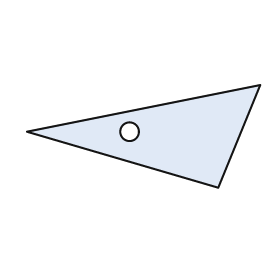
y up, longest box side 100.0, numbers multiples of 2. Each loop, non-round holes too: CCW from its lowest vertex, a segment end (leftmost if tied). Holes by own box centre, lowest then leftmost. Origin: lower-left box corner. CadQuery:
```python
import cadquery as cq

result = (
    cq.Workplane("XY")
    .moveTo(82.0, 0.0)
    .lineTo(100.0, 44.0)
    .lineTo(0.0, 24.0)
    .close()
    .moveTo(44.0, 24.0)
    .circle(4.0)
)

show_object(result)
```